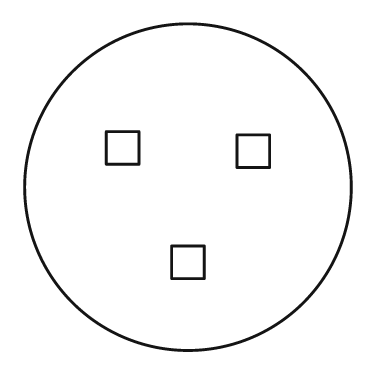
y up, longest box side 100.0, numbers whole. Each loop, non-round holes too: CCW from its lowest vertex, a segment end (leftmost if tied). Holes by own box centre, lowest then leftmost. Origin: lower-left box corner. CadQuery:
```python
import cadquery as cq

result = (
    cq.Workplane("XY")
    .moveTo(50.0, 50.0)
    .circle(50.0)
    .moveTo(45.0, 22.0)
    .lineTo(55.0, 22.0)
    .lineTo(55.0, 32.0)
    .lineTo(45.0, 32.0)
    .close()
    .moveTo(65.0, 56.0)
    .lineTo(75.0, 56.0)
    .lineTo(75.0, 66.0)
    .lineTo(65.0, 66.0)
    .close()
    .moveTo(25.0, 57.0)
    .lineTo(35.0, 57.0)
    .lineTo(35.0, 67.0)
    .lineTo(25.0, 67.0)
    .close()
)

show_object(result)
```